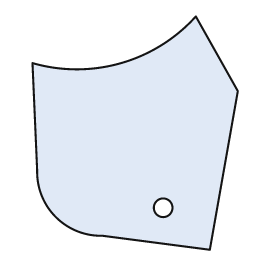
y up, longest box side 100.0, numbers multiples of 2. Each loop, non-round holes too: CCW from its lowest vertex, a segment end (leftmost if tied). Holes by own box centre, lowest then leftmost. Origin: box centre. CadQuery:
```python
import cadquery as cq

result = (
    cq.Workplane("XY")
    .moveTo(32.0, -50.0)
    .lineTo(44.0, 18.0)
    .lineTo(26.0, 50.0)
    .threePointArc((-6.0, 30.0), (-44.0, 30.0))
    .lineTo(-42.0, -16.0)
    .threePointArc((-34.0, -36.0), (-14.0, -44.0))
    .close()
    .moveTo(12.0, -32.0)
    .circle(4.0)
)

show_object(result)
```